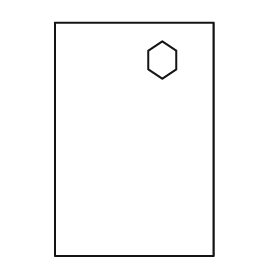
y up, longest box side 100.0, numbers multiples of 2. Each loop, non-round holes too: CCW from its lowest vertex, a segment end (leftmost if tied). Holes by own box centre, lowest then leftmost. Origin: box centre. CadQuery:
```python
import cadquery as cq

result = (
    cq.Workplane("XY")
    .moveTo(-34.0, -50.0)
    .lineTo(34.0, -50.0)
    .lineTo(34.0, 50.0)
    .lineTo(-34.0, 50.0)
    .close()
    .moveTo(12.0, 26.0)
    .lineTo(18.0, 30.0)
    .lineTo(18.0, 38.0)
    .lineTo(12.0, 42.0)
    .lineTo(6.0, 38.0)
    .lineTo(6.0, 30.0)
    .close()
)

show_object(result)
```